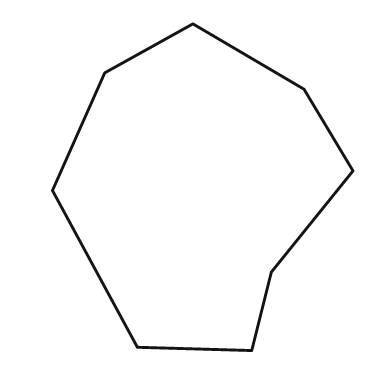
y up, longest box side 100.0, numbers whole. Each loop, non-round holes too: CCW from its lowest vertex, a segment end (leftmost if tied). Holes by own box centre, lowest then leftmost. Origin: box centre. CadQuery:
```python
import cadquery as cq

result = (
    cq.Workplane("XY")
    .moveTo(15.0, -50.0)
    .lineTo(21.0, -26.0)
    .lineTo(46.0, 5.0)
    .lineTo(31.0, 30.0)
    .lineTo(-3.0, 50.0)
    .lineTo(-30.0, 35.0)
    .lineTo(-46.0, -1.0)
    .lineTo(-20.0, -49.0)
    .close()
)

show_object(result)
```